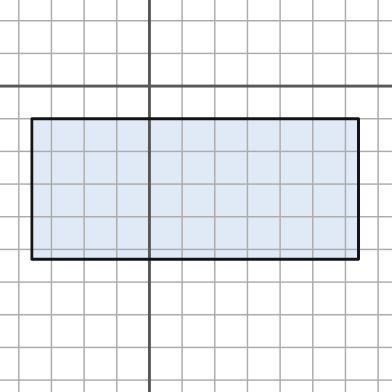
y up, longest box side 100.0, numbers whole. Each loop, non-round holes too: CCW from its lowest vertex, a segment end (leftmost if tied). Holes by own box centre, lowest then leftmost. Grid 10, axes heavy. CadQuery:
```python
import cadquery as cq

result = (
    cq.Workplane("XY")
    .moveTo(-36.0, -53.0)
    .lineTo(64.0, -53.0)
    .lineTo(64.0, -10.0)
    .lineTo(-36.0, -10.0)
    .close()
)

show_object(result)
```